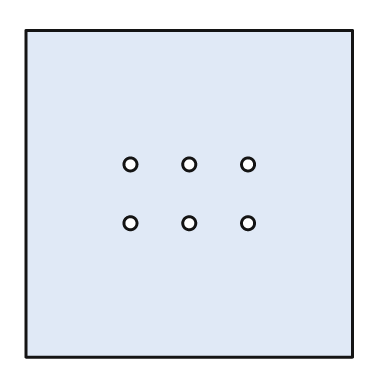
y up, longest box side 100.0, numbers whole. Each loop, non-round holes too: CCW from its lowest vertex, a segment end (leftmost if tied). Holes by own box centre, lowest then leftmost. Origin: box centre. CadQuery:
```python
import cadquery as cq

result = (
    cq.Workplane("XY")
    .moveTo(-50.0, -50.0)
    .lineTo(50.0, -50.0)
    .lineTo(50.0, 50.0)
    .lineTo(-50.0, 50.0)
    .close()
    .moveTo(-18.0, -9.0)
    .circle(2.0)
    .moveTo(0.0, -9.0)
    .circle(2.0)
    .moveTo(18.0, -9.0)
    .circle(2.0)
    .moveTo(-18.0, 9.0)
    .circle(2.0)
    .moveTo(0.0, 9.0)
    .circle(2.0)
    .moveTo(18.0, 9.0)
    .circle(2.0)
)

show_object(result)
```